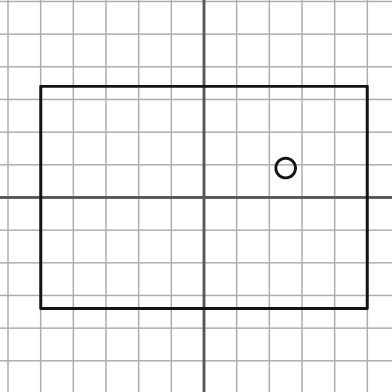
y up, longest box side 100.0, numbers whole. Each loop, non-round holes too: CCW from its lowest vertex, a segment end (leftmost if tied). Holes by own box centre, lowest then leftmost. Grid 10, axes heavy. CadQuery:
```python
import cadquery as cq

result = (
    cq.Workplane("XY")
    .moveTo(-50.0, -34.0)
    .lineTo(50.0, -34.0)
    .lineTo(50.0, 34.0)
    .lineTo(-50.0, 34.0)
    .close()
    .moveTo(25.0, 9.0)
    .circle(3.0)
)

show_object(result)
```